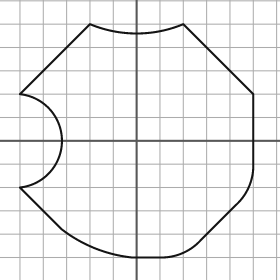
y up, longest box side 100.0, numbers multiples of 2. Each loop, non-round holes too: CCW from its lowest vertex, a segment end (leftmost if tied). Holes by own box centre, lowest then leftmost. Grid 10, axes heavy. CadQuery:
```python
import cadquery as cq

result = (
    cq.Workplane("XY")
    .moveTo(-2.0, -50.0)
    .lineTo(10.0, -50.0)
    .threePointArc((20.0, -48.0), (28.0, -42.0))
    .lineTo(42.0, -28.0)
    .threePointArc((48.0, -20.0), (50.0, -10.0))
    .lineTo(50.0, 20.0)
    .lineTo(20.0, 50.0)
    .threePointArc((0.0, 46.0), (-20.0, 50.0))
    .lineTo(-50.0, 20.0)
    .threePointArc((-32.0, 0.0), (-50.0, -20.0))
    .lineTo(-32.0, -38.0)
    .threePointArc((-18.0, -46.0), (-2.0, -50.0))
    .close()
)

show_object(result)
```